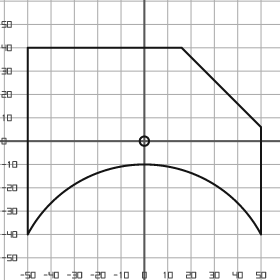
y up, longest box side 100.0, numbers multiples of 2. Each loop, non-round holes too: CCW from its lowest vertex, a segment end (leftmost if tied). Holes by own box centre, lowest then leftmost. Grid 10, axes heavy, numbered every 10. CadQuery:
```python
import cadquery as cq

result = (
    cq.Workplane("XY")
    .moveTo(-50.0, -40.0)
    .threePointArc((0.0, -10.0), (50.0, -40.0))
    .lineTo(50.0, 6.0)
    .lineTo(16.0, 40.0)
    .lineTo(-50.0, 40.0)
    .close()
    .moveTo(0.0, 0.0)
    .circle(2.0)
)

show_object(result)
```